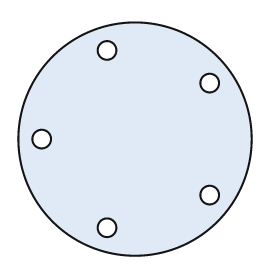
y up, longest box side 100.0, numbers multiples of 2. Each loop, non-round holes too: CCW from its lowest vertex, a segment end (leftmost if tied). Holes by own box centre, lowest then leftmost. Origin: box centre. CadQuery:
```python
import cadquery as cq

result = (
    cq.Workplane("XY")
    .moveTo(0.0, 0.0)
    .circle(50.0)
    .moveTo(-12.0, -38.0)
    .circle(4.0)
    .moveTo(32.0, -24.0)
    .circle(4.0)
    .moveTo(-40.0, 0.0)
    .circle(4.0)
    .moveTo(32.0, 24.0)
    .circle(4.0)
    .moveTo(-12.0, 38.0)
    .circle(4.0)
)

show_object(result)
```